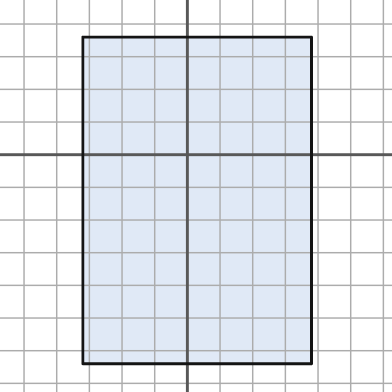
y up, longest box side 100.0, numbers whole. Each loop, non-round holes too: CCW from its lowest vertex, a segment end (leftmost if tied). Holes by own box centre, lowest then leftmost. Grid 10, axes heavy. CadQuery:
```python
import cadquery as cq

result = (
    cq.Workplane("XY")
    .moveTo(-32.0, -64.0)
    .lineTo(38.0, -64.0)
    .lineTo(38.0, 36.0)
    .lineTo(-32.0, 36.0)
    .close()
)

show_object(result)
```